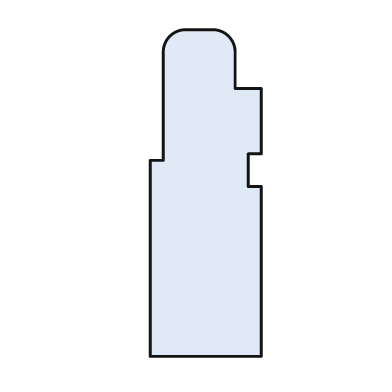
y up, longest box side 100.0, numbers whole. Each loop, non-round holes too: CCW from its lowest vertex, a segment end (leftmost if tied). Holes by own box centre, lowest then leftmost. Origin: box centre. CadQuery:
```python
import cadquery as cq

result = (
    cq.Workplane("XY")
    .moveTo(-17.0, -50.0)
    .lineTo(17.0, -50.0)
    .lineTo(17.0, 2.0)
    .lineTo(13.0, 2.0)
    .lineTo(13.0, 12.0)
    .lineTo(17.0, 12.0)
    .lineTo(17.0, 32.0)
    .lineTo(9.0, 32.0)
    .lineTo(9.0, 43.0)
    .threePointArc((7.0, 48.0), (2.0, 50.0))
    .lineTo(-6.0, 50.0)
    .threePointArc((-11.0, 48.0), (-13.0, 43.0))
    .lineTo(-13.0, 10.0)
    .lineTo(-17.0, 10.0)
    .close()
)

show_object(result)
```